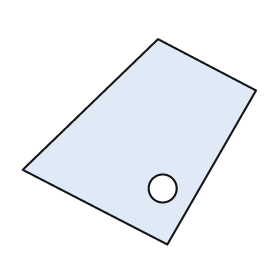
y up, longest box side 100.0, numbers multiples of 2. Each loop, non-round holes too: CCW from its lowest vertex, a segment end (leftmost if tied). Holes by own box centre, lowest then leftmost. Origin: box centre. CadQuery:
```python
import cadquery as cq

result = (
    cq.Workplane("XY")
    .moveTo(12.0, -44.0)
    .lineTo(50.0, 22.0)
    .lineTo(8.0, 44.0)
    .lineTo(-50.0, -12.0)
    .close()
    .moveTo(10.0, -20.0)
    .circle(6.0)
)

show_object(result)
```